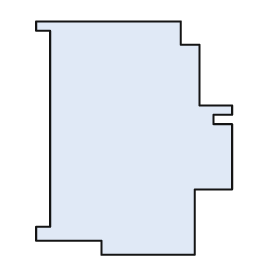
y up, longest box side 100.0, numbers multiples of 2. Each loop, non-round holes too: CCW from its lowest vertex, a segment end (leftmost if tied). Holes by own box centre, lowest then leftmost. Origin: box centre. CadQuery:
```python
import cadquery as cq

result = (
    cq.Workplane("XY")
    .moveTo(-14.0, -50.0)
    .lineTo(26.0, -50.0)
    .lineTo(26.0, -22.0)
    .lineTo(42.0, -22.0)
    .lineTo(42.0, 6.0)
    .lineTo(34.0, 6.0)
    .lineTo(34.0, 10.0)
    .lineTo(42.0, 10.0)
    .lineTo(42.0, 14.0)
    .lineTo(28.0, 14.0)
    .lineTo(28.0, 40.0)
    .lineTo(20.0, 40.0)
    .lineTo(20.0, 50.0)
    .lineTo(-42.0, 50.0)
    .lineTo(-42.0, 46.0)
    .lineTo(-36.0, 46.0)
    .lineTo(-36.0, -38.0)
    .lineTo(-42.0, -38.0)
    .lineTo(-42.0, -44.0)
    .lineTo(-14.0, -44.0)
    .close()
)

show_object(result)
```